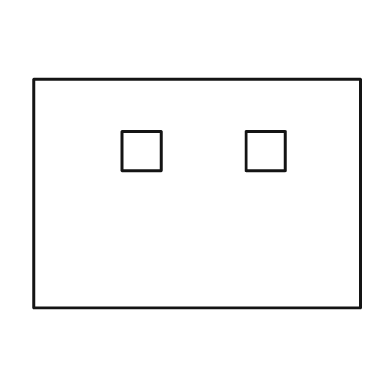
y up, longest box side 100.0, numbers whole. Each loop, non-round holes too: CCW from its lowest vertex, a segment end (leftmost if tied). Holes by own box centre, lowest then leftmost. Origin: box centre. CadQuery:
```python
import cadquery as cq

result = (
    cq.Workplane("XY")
    .moveTo(-50.0, -35.0)
    .lineTo(50.0, -35.0)
    .lineTo(50.0, 35.0)
    .lineTo(-50.0, 35.0)
    .close()
    .moveTo(-23.0, 7.0)
    .lineTo(-11.0, 7.0)
    .lineTo(-11.0, 19.0)
    .lineTo(-23.0, 19.0)
    .close()
    .moveTo(15.0, 7.0)
    .lineTo(27.0, 7.0)
    .lineTo(27.0, 19.0)
    .lineTo(15.0, 19.0)
    .close()
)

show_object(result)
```